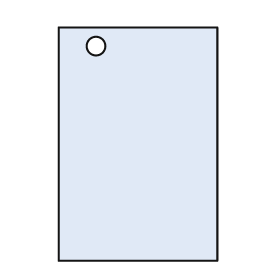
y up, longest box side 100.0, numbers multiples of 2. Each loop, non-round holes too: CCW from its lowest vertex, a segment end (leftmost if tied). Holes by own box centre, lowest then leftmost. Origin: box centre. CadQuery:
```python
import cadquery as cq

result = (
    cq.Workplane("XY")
    .moveTo(-34.0, -50.0)
    .lineTo(34.0, -50.0)
    .lineTo(34.0, 50.0)
    .lineTo(-34.0, 50.0)
    .close()
    .moveTo(-18.0, 42.0)
    .circle(4.0)
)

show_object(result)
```